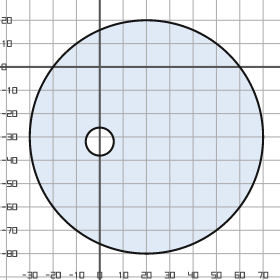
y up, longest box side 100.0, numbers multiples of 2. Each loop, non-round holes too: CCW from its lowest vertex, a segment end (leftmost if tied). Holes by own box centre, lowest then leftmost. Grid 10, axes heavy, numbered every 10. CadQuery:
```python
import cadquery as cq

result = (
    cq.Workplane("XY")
    .moveTo(20.0, -30.0)
    .circle(50.0)
    .moveTo(0.0, -32.0)
    .circle(6.0)
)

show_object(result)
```